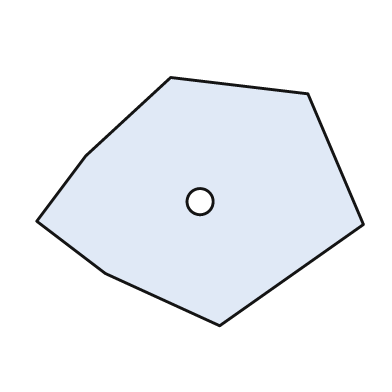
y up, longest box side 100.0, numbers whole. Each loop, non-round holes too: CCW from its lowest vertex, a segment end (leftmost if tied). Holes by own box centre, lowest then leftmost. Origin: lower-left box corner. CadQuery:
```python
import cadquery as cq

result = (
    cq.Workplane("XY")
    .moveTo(56.0, 0.0)
    .lineTo(100.0, 31.0)
    .lineTo(83.0, 71.0)
    .lineTo(41.0, 76.0)
    .lineTo(15.0, 52.0)
    .lineTo(0.0, 32.0)
    .lineTo(21.0, 16.0)
    .close()
    .moveTo(50.0, 38.0)
    .circle(4.0)
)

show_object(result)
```